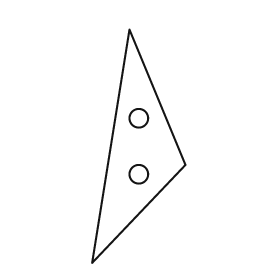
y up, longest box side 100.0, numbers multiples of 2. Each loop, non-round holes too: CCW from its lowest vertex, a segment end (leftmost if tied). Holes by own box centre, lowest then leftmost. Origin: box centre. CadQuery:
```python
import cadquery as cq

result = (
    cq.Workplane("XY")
    .moveTo(-20.0, -50.0)
    .lineTo(20.0, -8.0)
    .lineTo(-4.0, 50.0)
    .close()
    .moveTo(0.0, -12.0)
    .circle(4.0)
    .moveTo(0.0, 12.0)
    .circle(4.0)
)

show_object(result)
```